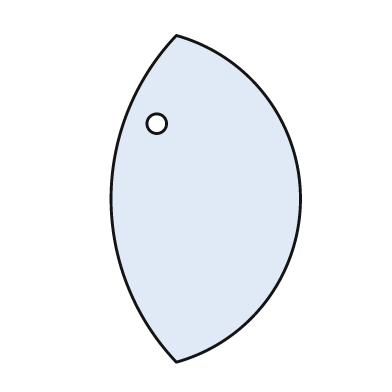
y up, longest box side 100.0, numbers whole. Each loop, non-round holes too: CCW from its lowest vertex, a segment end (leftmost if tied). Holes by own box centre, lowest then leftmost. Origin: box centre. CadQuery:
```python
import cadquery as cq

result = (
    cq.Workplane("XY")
    .moveTo(-9.0, -50.0)
    .threePointArc((29.0, 0.0), (-9.0, 50.0))
    .threePointArc((-29.0, 0.0), (-9.0, -50.0))
    .close()
    .moveTo(-15.0, 23.0)
    .circle(3.0)
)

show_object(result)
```